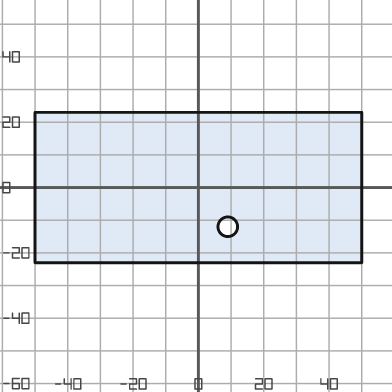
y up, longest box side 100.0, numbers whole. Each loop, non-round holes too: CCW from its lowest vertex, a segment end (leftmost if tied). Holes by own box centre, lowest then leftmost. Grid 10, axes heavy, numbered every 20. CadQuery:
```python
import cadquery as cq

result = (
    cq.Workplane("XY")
    .moveTo(-50.0, -23.0)
    .lineTo(50.0, -23.0)
    .lineTo(50.0, 23.0)
    .lineTo(-50.0, 23.0)
    .close()
    .moveTo(9.0, -12.0)
    .circle(3.0)
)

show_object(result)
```